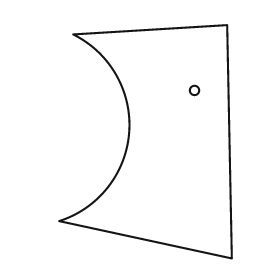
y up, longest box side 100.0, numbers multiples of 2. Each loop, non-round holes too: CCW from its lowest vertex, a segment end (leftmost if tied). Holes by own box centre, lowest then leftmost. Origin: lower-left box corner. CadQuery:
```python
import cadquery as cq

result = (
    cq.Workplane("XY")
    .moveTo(74.0, 0.0)
    .lineTo(72.0, 100.0)
    .lineTo(6.0, 96.0)
    .threePointArc((30.0, 54.0), (0.0, 16.0))
    .close()
    .moveTo(58.0, 72.0)
    .circle(2.0)
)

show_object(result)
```